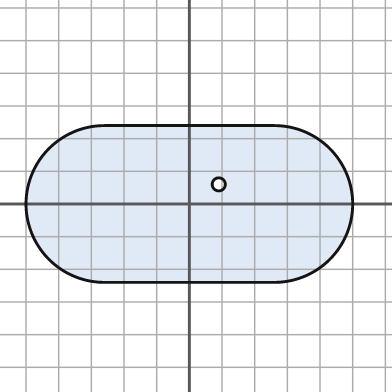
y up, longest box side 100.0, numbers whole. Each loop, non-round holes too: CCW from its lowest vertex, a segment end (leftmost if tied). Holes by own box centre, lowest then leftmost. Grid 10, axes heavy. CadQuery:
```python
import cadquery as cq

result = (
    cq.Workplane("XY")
    .moveTo(-26.0, -24.0)
    .lineTo(26.0, -24.0)
    .threePointArc((50.0, 0.0), (26.0, 24.0))
    .lineTo(-26.0, 24.0)
    .threePointArc((-50.0, 0.0), (-26.0, -24.0))
    .close()
    .moveTo(9.0, 6.0)
    .circle(2.0)
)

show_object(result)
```